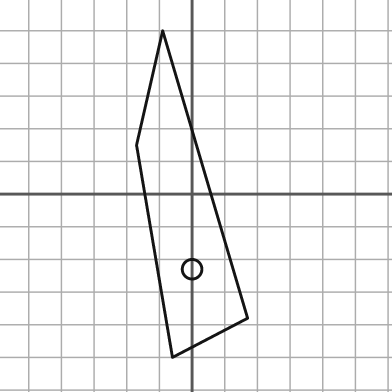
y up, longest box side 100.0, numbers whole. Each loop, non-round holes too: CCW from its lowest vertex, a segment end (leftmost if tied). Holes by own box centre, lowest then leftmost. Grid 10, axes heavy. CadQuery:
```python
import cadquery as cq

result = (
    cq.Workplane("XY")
    .moveTo(-6.0, -50.0)
    .lineTo(17.0, -38.0)
    .lineTo(-9.0, 50.0)
    .lineTo(-17.0, 15.0)
    .close()
    .moveTo(0.0, -23.0)
    .circle(3.0)
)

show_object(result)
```